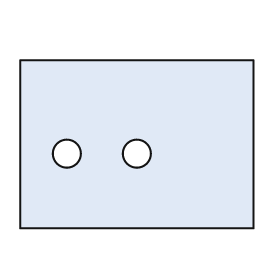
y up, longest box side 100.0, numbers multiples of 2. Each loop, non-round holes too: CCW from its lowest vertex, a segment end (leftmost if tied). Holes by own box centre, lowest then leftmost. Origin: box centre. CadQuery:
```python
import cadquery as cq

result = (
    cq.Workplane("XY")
    .moveTo(-50.0, -36.0)
    .lineTo(50.0, -36.0)
    .lineTo(50.0, 36.0)
    .lineTo(-50.0, 36.0)
    .close()
    .moveTo(-30.0, -4.0)
    .circle(6.0)
    .moveTo(0.0, -4.0)
    .circle(6.0)
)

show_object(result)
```